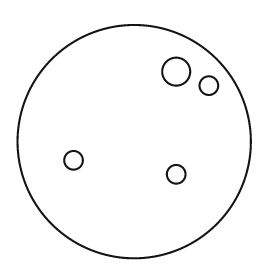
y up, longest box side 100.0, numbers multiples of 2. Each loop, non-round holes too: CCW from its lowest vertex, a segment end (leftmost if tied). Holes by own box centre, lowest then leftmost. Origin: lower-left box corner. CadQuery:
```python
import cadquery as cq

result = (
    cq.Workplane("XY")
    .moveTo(50.0, 50.0)
    .circle(50.0)
    .moveTo(68.0, 36.0)
    .circle(4.0)
    .moveTo(24.0, 42.0)
    .circle(4.0)
    .moveTo(82.0, 74.0)
    .circle(4.0)
    .moveTo(68.0, 80.0)
    .circle(6.0)
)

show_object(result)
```